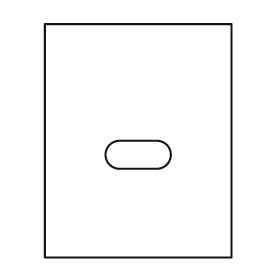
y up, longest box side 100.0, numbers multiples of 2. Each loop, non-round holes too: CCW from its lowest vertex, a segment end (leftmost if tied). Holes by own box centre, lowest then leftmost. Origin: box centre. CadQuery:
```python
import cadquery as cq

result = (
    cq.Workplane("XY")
    .moveTo(-40.0, -50.0)
    .lineTo(40.0, -50.0)
    .lineTo(40.0, 50.0)
    .lineTo(-40.0, 50.0)
    .close()
    .moveTo(-8.0, -12.0)
    .lineTo(8.0, -12.0)
    .threePointArc((14.0, -6.0), (8.0, 0.0))
    .lineTo(-8.0, 0.0)
    .threePointArc((-14.0, -6.0), (-8.0, -12.0))
    .close()
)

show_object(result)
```